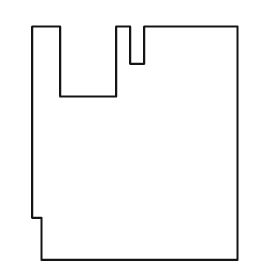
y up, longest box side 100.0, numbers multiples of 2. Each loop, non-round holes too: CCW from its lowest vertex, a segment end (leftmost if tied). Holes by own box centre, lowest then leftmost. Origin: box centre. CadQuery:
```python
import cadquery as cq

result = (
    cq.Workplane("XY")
    .moveTo(-40.0, -50.0)
    .lineTo(44.0, -50.0)
    .lineTo(44.0, 50.0)
    .lineTo(4.0, 50.0)
    .lineTo(4.0, 34.0)
    .lineTo(-2.0, 34.0)
    .lineTo(-2.0, 50.0)
    .lineTo(-8.0, 50.0)
    .lineTo(-8.0, 20.0)
    .lineTo(-32.0, 20.0)
    .lineTo(-32.0, 50.0)
    .lineTo(-44.0, 50.0)
    .lineTo(-44.0, -32.0)
    .lineTo(-40.0, -32.0)
    .close()
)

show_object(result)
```